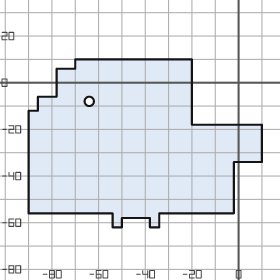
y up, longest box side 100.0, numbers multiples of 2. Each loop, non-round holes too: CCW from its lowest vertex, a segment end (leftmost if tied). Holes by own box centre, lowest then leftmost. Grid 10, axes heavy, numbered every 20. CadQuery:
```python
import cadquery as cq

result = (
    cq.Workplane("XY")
    .moveTo(-54.0, -62.0)
    .lineTo(-50.0, -62.0)
    .lineTo(-50.0, -58.0)
    .lineTo(-38.0, -58.0)
    .lineTo(-38.0, -62.0)
    .lineTo(-34.0, -62.0)
    .lineTo(-34.0, -56.0)
    .lineTo(-2.0, -56.0)
    .lineTo(-2.0, -34.0)
    .lineTo(10.0, -34.0)
    .lineTo(10.0, -18.0)
    .lineTo(-20.0, -18.0)
    .lineTo(-20.0, 10.0)
    .lineTo(-70.0, 10.0)
    .lineTo(-70.0, 6.0)
    .lineTo(-78.0, 6.0)
    .lineTo(-78.0, -6.0)
    .lineTo(-86.0, -6.0)
    .lineTo(-86.0, -12.0)
    .lineTo(-90.0, -12.0)
    .lineTo(-90.0, -56.0)
    .lineTo(-54.0, -56.0)
    .close()
    .moveTo(-64.0, -8.0)
    .circle(2.0)
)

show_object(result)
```